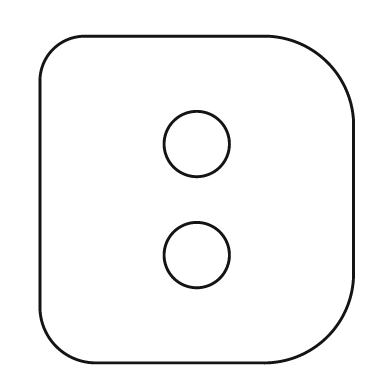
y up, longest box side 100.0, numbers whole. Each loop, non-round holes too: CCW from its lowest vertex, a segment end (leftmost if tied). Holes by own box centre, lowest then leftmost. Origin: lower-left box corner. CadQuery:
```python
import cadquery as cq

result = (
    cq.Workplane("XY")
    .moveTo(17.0, 0.0)
    .lineTo(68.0, 0.0)
    .threePointArc((88.0, 8.0), (96.0, 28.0))
    .lineTo(96.0, 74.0)
    .threePointArc((88.0, 92.0), (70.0, 100.0))
    .lineTo(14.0, 100.0)
    .threePointArc((4.0, 96.0), (0.0, 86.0))
    .lineTo(0.0, 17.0)
    .threePointArc((5.0, 5.0), (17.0, 0.0))
    .close()
    .moveTo(48.0, 33.0)
    .circle(10.0)
    .moveTo(48.0, 67.0)
    .circle(10.0)
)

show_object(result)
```